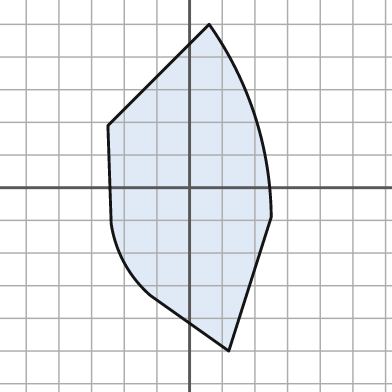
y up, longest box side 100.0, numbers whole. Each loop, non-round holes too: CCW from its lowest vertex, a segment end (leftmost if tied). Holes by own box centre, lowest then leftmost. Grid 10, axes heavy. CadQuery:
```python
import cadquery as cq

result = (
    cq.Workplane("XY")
    .moveTo(12.0, -50.0)
    .lineTo(25.0, -9.0)
    .threePointArc((20.0, 22.0), (6.0, 50.0))
    .lineTo(-25.0, 19.0)
    .lineTo(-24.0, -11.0)
    .threePointArc((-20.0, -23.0), (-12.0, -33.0))
    .close()
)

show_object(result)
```